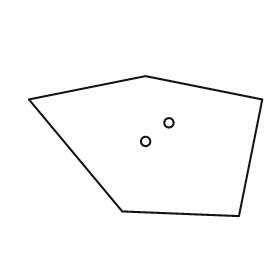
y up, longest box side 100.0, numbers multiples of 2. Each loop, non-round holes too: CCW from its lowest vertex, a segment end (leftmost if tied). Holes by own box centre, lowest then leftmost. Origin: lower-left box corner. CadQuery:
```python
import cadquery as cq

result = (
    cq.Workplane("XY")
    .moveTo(90.0, 0.0)
    .lineTo(100.0, 50.0)
    .lineTo(50.0, 60.0)
    .lineTo(0.0, 50.0)
    .lineTo(40.0, 2.0)
    .close()
    .moveTo(50.0, 32.0)
    .circle(2.0)
    .moveTo(60.0, 40.0)
    .circle(2.0)
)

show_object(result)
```